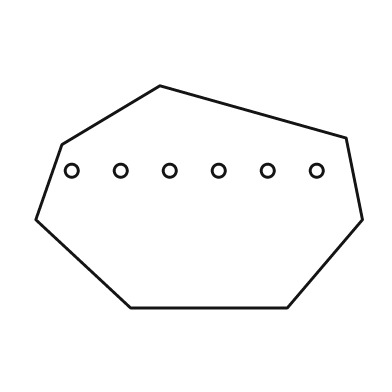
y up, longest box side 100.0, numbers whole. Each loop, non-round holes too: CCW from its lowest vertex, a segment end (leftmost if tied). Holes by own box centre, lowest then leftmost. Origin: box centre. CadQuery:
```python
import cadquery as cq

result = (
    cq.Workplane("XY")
    .moveTo(-21.0, -34.0)
    .lineTo(27.0, -34.0)
    .lineTo(50.0, -7.0)
    .lineTo(45.0, 18.0)
    .lineTo(-12.0, 34.0)
    .lineTo(-42.0, 16.0)
    .lineTo(-50.0, -7.0)
    .close()
    .moveTo(-39.0, 8.0)
    .circle(2.0)
    .moveTo(-24.0, 8.0)
    .circle(2.0)
    .moveTo(-9.0, 8.0)
    .circle(2.0)
    .moveTo(6.0, 8.0)
    .circle(2.0)
    .moveTo(21.0, 8.0)
    .circle(2.0)
    .moveTo(36.0, 8.0)
    .circle(2.0)
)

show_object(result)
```